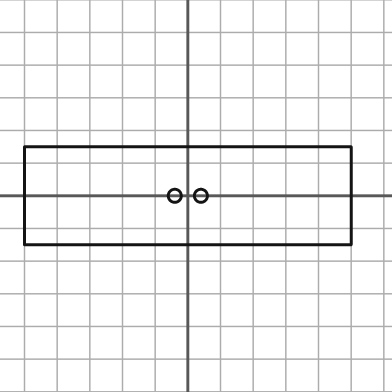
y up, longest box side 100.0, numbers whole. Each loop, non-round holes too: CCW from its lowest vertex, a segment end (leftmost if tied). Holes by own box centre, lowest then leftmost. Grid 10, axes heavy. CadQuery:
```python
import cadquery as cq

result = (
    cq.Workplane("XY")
    .moveTo(-50.0, -15.0)
    .lineTo(50.0, -15.0)
    .lineTo(50.0, 15.0)
    .lineTo(-50.0, 15.0)
    .close()
    .moveTo(-4.0, 0.0)
    .circle(2.0)
    .moveTo(4.0, 0.0)
    .circle(2.0)
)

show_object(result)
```